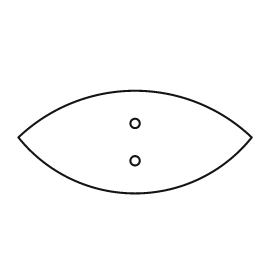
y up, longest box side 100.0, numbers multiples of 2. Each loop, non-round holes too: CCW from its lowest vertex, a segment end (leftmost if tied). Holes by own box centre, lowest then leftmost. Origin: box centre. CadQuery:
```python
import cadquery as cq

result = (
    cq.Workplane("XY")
    .moveTo(-50.0, 2.0)
    .threePointArc((0.0, -22.0), (50.0, 2.0))
    .threePointArc((0.0, 22.0), (-50.0, 2.0))
    .close()
    .moveTo(0.0, -8.0)
    .circle(2.0)
    .moveTo(0.0, 8.0)
    .circle(2.0)
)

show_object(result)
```